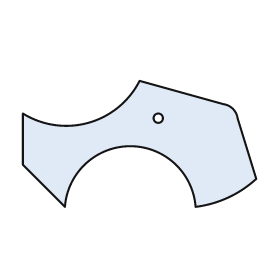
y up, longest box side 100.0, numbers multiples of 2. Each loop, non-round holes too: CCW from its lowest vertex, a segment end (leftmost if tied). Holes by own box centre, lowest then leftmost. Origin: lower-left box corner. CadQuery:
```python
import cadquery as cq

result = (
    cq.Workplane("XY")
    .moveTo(18.0, 0.0)
    .threePointArc((46.0, 26.0), (74.0, 0.0))
    .threePointArc((88.0, 4.0), (100.0, 12.0))
    .lineTo(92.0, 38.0)
    .threePointArc((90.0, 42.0), (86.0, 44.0))
    .lineTo(50.0, 54.0)
    .threePointArc((28.0, 36.0), (0.0, 40.0))
    .lineTo(0.0, 18.0)
    .close()
    .moveTo(58.0, 38.0)
    .circle(2.0)
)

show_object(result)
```